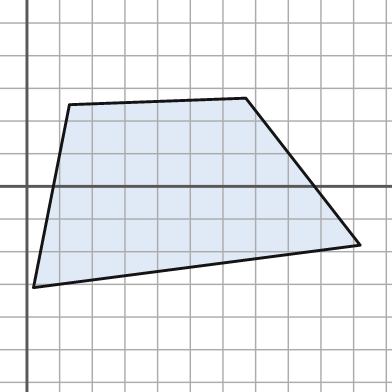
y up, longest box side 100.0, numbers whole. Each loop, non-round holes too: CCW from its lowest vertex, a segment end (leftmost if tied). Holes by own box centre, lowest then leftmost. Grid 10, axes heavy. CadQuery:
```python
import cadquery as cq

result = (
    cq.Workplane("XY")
    .moveTo(2.0, -31.0)
    .lineTo(102.0, -18.0)
    .lineTo(67.0, 27.0)
    .lineTo(13.0, 25.0)
    .close()
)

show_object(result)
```